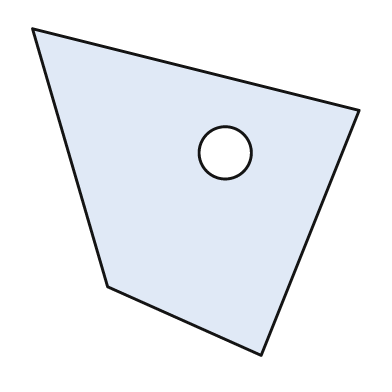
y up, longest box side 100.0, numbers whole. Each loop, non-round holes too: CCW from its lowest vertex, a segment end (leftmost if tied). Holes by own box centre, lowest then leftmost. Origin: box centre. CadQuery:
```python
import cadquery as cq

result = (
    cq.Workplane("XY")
    .moveTo(20.0, -50.0)
    .lineTo(50.0, 25.0)
    .lineTo(-50.0, 50.0)
    .lineTo(-27.0, -29.0)
    .close()
    .moveTo(9.0, 12.0)
    .circle(8.0)
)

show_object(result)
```